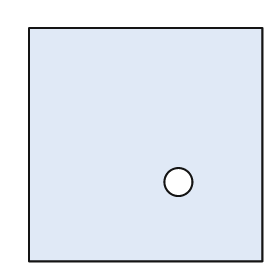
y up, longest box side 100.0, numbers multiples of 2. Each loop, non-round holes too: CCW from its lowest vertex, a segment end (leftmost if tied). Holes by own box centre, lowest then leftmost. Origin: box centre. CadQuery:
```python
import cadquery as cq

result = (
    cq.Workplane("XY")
    .moveTo(-50.0, -50.0)
    .lineTo(50.0, -50.0)
    .lineTo(50.0, 50.0)
    .lineTo(-50.0, 50.0)
    .close()
    .moveTo(14.0, -16.0)
    .circle(6.0)
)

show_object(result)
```